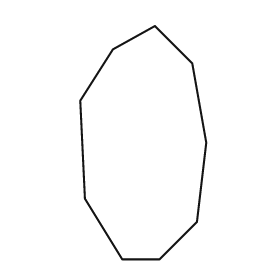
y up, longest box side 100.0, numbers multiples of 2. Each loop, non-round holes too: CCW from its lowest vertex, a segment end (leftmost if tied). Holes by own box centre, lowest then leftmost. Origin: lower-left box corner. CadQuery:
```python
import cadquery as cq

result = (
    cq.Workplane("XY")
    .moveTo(18.0, 0.0)
    .lineTo(34.0, 0.0)
    .lineTo(50.0, 16.0)
    .lineTo(54.0, 50.0)
    .lineTo(48.0, 84.0)
    .lineTo(32.0, 100.0)
    .lineTo(14.0, 90.0)
    .lineTo(0.0, 68.0)
    .lineTo(2.0, 26.0)
    .close()
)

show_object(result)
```